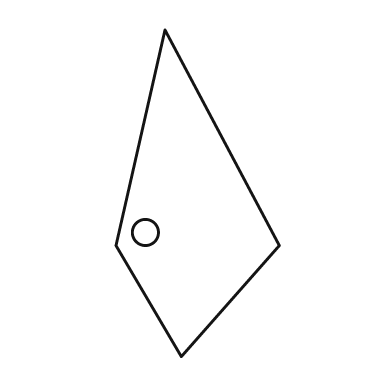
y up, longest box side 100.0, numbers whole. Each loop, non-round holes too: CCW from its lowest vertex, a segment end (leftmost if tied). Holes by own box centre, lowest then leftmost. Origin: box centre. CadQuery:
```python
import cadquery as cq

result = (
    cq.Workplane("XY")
    .moveTo(-5.0, -50.0)
    .lineTo(25.0, -16.0)
    .lineTo(-10.0, 50.0)
    .lineTo(-25.0, -16.0)
    .close()
    .moveTo(-16.0, -12.0)
    .circle(4.0)
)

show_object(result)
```